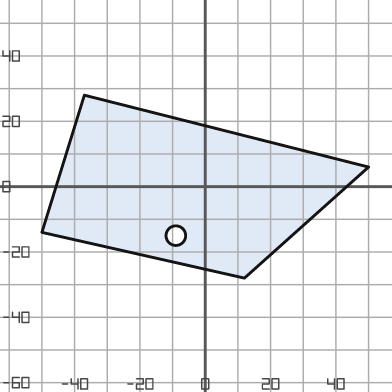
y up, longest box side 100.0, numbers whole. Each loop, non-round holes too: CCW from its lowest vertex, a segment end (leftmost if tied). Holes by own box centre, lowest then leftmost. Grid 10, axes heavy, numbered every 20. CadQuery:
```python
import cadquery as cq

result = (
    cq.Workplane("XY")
    .moveTo(12.0, -28.0)
    .lineTo(50.0, 6.0)
    .lineTo(-37.0, 28.0)
    .lineTo(-50.0, -14.0)
    .close()
    .moveTo(-9.0, -15.0)
    .circle(3.0)
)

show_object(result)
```